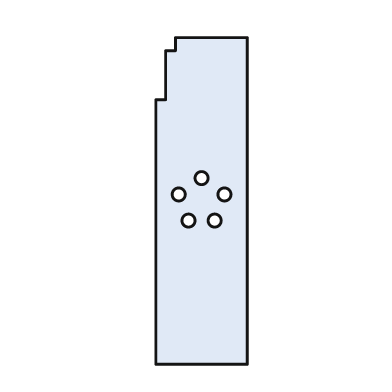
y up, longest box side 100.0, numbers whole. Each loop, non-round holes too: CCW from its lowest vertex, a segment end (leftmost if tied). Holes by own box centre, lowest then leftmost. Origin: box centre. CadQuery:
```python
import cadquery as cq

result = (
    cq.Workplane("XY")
    .moveTo(-14.0, -50.0)
    .lineTo(14.0, -50.0)
    .lineTo(14.0, 50.0)
    .lineTo(-8.0, 50.0)
    .lineTo(-8.0, 46.0)
    .lineTo(-11.0, 46.0)
    .lineTo(-11.0, 31.0)
    .lineTo(-14.0, 31.0)
    .close()
    .moveTo(-4.0, -6.0)
    .circle(2.0)
    .moveTo(4.0, -6.0)
    .circle(2.0)
    .moveTo(-7.0, 2.0)
    .circle(2.0)
    .moveTo(7.0, 2.0)
    .circle(2.0)
    .moveTo(0.0, 7.0)
    .circle(2.0)
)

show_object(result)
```